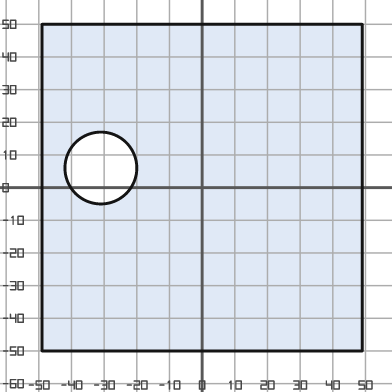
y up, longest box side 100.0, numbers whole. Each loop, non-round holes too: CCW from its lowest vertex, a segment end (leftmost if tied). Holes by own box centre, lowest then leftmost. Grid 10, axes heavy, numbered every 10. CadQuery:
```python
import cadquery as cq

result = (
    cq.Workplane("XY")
    .moveTo(-49.0, -50.0)
    .lineTo(49.0, -50.0)
    .lineTo(49.0, 50.0)
    .lineTo(-49.0, 50.0)
    .close()
    .moveTo(-31.0, 6.0)
    .circle(11.0)
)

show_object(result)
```